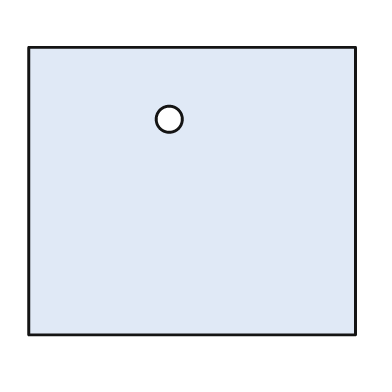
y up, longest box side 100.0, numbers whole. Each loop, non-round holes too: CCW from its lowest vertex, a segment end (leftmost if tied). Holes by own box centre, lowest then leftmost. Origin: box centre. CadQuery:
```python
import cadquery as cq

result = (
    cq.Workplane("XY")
    .moveTo(-50.0, -44.0)
    .lineTo(50.0, -44.0)
    .lineTo(50.0, 44.0)
    .lineTo(-50.0, 44.0)
    .close()
    .moveTo(-7.0, 22.0)
    .circle(4.0)
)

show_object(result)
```